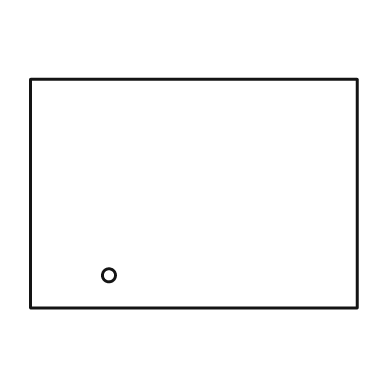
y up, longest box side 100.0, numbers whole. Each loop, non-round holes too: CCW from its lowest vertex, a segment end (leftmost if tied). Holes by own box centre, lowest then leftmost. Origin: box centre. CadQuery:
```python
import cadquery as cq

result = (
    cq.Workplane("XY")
    .moveTo(-50.0, -35.0)
    .lineTo(50.0, -35.0)
    .lineTo(50.0, 35.0)
    .lineTo(-50.0, 35.0)
    .close()
    .moveTo(-26.0, -25.0)
    .circle(2.0)
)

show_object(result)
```